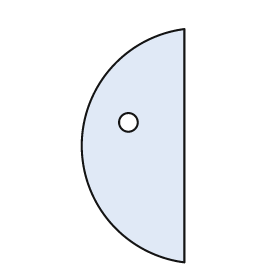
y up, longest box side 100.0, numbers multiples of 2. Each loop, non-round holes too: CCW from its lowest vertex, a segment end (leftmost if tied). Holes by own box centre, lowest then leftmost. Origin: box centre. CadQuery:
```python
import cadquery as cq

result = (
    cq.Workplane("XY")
    .moveTo(22.0, -50.0)
    .lineTo(22.0, 50.0)
    .threePointArc((-22.0, 0.0), (22.0, -50.0))
    .close()
    .moveTo(-2.0, 10.0)
    .circle(4.0)
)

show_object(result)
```